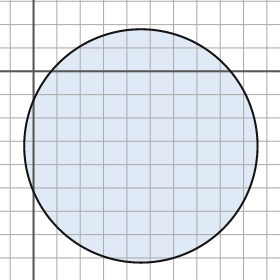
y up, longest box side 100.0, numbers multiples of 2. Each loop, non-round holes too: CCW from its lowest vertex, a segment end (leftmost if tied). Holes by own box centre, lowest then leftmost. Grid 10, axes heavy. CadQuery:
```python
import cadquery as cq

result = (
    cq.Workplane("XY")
    .moveTo(46.0, -32.0)
    .circle(50.0)
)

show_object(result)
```